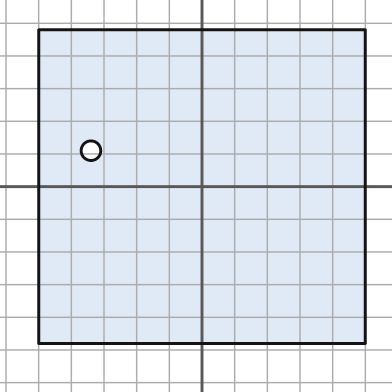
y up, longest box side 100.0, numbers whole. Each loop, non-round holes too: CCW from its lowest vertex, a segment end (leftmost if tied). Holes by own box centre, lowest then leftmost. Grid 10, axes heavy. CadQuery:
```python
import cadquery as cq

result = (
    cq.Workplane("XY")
    .moveTo(-50.0, -48.0)
    .lineTo(50.0, -48.0)
    .lineTo(50.0, 48.0)
    .lineTo(-50.0, 48.0)
    .close()
    .moveTo(-34.0, 11.0)
    .circle(3.0)
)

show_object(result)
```